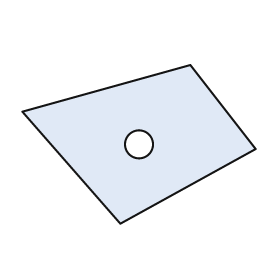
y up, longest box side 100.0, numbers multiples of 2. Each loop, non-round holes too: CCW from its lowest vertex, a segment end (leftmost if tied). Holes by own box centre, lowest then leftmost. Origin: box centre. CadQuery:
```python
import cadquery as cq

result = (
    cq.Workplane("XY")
    .moveTo(-8.0, -34.0)
    .lineTo(50.0, -2.0)
    .lineTo(22.0, 34.0)
    .lineTo(-50.0, 14.0)
    .close()
    .moveTo(0.0, 0.0)
    .circle(6.0)
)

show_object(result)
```